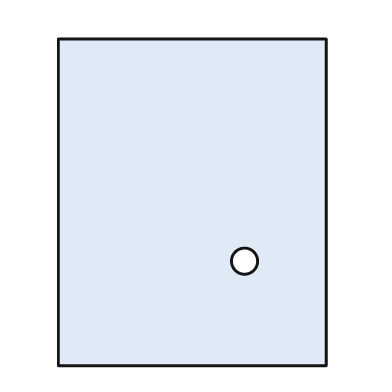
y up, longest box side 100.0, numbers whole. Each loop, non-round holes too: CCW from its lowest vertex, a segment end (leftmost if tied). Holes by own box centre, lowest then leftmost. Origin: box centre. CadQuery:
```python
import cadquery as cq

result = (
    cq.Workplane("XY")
    .moveTo(-41.0, -50.0)
    .lineTo(41.0, -50.0)
    .lineTo(41.0, 50.0)
    .lineTo(-41.0, 50.0)
    .close()
    .moveTo(16.0, -18.0)
    .circle(4.0)
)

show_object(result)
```